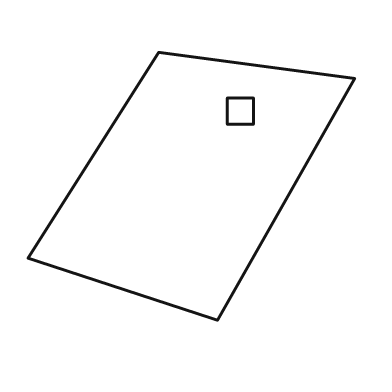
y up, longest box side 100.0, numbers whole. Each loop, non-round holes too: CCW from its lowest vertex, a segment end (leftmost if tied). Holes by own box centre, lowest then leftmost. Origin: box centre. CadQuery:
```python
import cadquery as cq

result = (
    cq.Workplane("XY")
    .moveTo(8.0, -41.0)
    .lineTo(50.0, 33.0)
    .lineTo(-10.0, 41.0)
    .lineTo(-50.0, -22.0)
    .close()
    .moveTo(11.0, 19.0)
    .lineTo(19.0, 19.0)
    .lineTo(19.0, 27.0)
    .lineTo(11.0, 27.0)
    .close()
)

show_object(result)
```